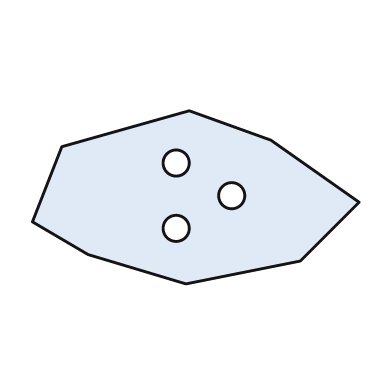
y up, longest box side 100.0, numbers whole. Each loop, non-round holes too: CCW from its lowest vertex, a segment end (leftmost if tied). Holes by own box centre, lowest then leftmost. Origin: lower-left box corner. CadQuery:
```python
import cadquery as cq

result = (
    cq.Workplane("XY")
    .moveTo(47.0, 0.0)
    .lineTo(82.0, 7.0)
    .lineTo(100.0, 25.0)
    .lineTo(73.0, 44.0)
    .lineTo(48.0, 53.0)
    .lineTo(9.0, 42.0)
    .lineTo(0.0, 19.0)
    .lineTo(17.0, 9.0)
    .close()
    .moveTo(44.0, 17.0)
    .circle(4.0)
    .moveTo(61.0, 27.0)
    .circle(4.0)
    .moveTo(44.0, 37.0)
    .circle(4.0)
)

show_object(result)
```